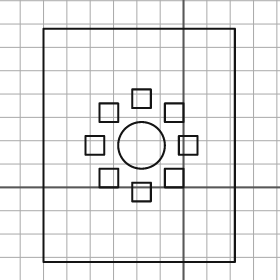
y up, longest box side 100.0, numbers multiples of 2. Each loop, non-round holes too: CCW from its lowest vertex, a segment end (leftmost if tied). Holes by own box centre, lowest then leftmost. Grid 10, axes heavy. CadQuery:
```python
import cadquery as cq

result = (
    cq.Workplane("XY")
    .moveTo(-60.0, -32.0)
    .lineTo(22.0, -32.0)
    .lineTo(22.0, 68.0)
    .lineTo(-60.0, 68.0)
    .close()
    .moveTo(-22.0, -6.0)
    .lineTo(-14.0, -6.0)
    .lineTo(-14.0, 2.0)
    .lineTo(-22.0, 2.0)
    .close()
    .moveTo(-36.0, 0.0)
    .lineTo(-28.0, 0.0)
    .lineTo(-28.0, 8.0)
    .lineTo(-36.0, 8.0)
    .close()
    .moveTo(-8.0, 0.0)
    .lineTo(0.0, 0.0)
    .lineTo(0.0, 8.0)
    .lineTo(-8.0, 8.0)
    .close()
    .moveTo(-42.0, 14.0)
    .lineTo(-34.0, 14.0)
    .lineTo(-34.0, 22.0)
    .lineTo(-42.0, 22.0)
    .close()
    .moveTo(-18.0, 18.0)
    .circle(10.0)
    .moveTo(-2.0, 14.0)
    .lineTo(6.0, 14.0)
    .lineTo(6.0, 22.0)
    .lineTo(-2.0, 22.0)
    .close()
    .moveTo(-36.0, 28.0)
    .lineTo(-28.0, 28.0)
    .lineTo(-28.0, 36.0)
    .lineTo(-36.0, 36.0)
    .close()
    .moveTo(-8.0, 28.0)
    .lineTo(0.0, 28.0)
    .lineTo(0.0, 36.0)
    .lineTo(-8.0, 36.0)
    .close()
    .moveTo(-22.0, 34.0)
    .lineTo(-14.0, 34.0)
    .lineTo(-14.0, 42.0)
    .lineTo(-22.0, 42.0)
    .close()
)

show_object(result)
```